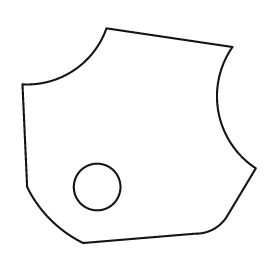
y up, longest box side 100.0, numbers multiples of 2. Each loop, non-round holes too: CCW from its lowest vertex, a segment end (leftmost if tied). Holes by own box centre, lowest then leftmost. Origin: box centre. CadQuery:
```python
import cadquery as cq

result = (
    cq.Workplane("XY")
    .moveTo(-24.0, -46.0)
    .lineTo(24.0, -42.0)
    .threePointArc((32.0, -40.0), (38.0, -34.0))
    .lineTo(50.0, -14.0)
    .threePointArc((34.0, 10.0), (40.0, 38.0))
    .lineTo(-14.0, 46.0)
    .threePointArc((-28.0, 28.0), (-50.0, 22.0))
    .lineTo(-48.0, -22.0)
    .threePointArc((-38.0, -36.0), (-24.0, -46.0))
    .close()
    .moveTo(-18.0, -22.0)
    .circle(10.0)
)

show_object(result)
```